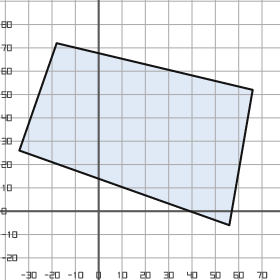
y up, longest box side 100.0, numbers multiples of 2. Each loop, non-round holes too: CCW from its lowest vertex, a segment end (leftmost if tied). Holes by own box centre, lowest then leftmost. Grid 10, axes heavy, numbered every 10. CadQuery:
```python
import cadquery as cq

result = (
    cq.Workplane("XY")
    .moveTo(56.0, -6.0)
    .lineTo(66.0, 52.0)
    .lineTo(-18.0, 72.0)
    .lineTo(-34.0, 26.0)
    .close()
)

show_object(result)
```